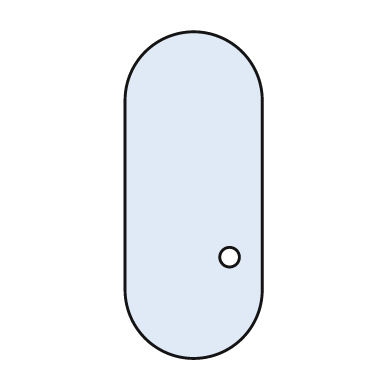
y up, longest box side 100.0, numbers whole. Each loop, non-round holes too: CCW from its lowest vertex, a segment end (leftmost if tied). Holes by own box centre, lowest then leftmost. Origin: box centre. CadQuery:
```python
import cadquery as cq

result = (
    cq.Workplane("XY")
    .moveTo(-21.0, -29.0)
    .threePointArc((0.0, -50.0), (21.0, -29.0))
    .lineTo(21.0, 29.0)
    .threePointArc((0.0, 50.0), (-21.0, 29.0))
    .close()
    .moveTo(11.0, -19.0)
    .circle(3.0)
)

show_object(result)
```